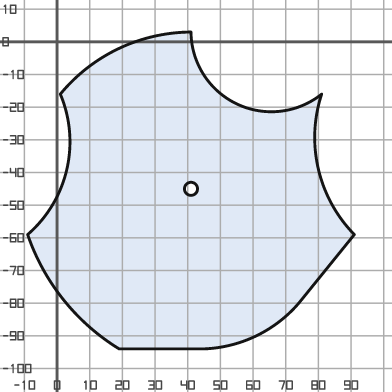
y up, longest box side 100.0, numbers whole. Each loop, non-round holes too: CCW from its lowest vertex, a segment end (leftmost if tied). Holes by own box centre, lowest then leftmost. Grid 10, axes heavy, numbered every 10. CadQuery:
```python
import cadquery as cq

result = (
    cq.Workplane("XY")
    .moveTo(19.0, -94.0)
    .lineTo(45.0, -94.0)
    .threePointArc((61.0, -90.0), (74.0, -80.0))
    .lineTo(91.0, -59.0)
    .threePointArc((80.0, -39.0), (81.0, -16.0))
    .threePointArc((55.0, -19.0), (41.0, 3.0))
    .threePointArc((19.0, -2.0), (1.0, -16.0))
    .threePointArc((3.0, -39.0), (-9.0, -59.0))
    .threePointArc((2.0, -79.0), (19.0, -94.0))
    .close()
    .moveTo(41.0, -45.0)
    .circle(2.0)
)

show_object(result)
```